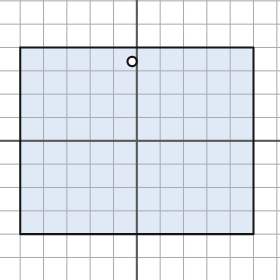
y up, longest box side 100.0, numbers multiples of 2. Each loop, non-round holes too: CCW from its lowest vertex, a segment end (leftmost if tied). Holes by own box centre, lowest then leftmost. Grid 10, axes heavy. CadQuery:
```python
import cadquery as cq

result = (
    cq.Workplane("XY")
    .moveTo(-50.0, -40.0)
    .lineTo(50.0, -40.0)
    .lineTo(50.0, 40.0)
    .lineTo(-50.0, 40.0)
    .close()
    .moveTo(-2.0, 34.0)
    .circle(2.0)
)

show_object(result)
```